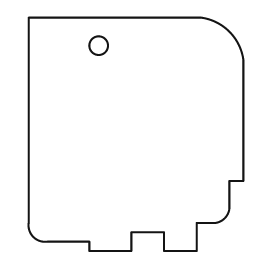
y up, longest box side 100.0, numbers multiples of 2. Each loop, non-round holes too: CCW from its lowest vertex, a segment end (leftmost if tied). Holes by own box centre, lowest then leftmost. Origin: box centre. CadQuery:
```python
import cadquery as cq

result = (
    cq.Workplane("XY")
    .moveTo(-20.0, -50.0)
    .lineTo(-2.0, -50.0)
    .lineTo(-2.0, -42.0)
    .lineTo(12.0, -42.0)
    .lineTo(12.0, -50.0)
    .lineTo(26.0, -50.0)
    .lineTo(26.0, -38.0)
    .lineTo(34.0, -38.0)
    .threePointArc((38.0, -36.0), (40.0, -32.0))
    .lineTo(40.0, -20.0)
    .lineTo(46.0, -20.0)
    .lineTo(46.0, 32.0)
    .threePointArc((40.0, 44.0), (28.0, 50.0))
    .lineTo(-46.0, 50.0)
    .lineTo(-46.0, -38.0)
    .threePointArc((-44.0, -44.0), (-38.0, -46.0))
    .lineTo(-20.0, -46.0)
    .close()
    .moveTo(-16.0, 38.0)
    .circle(4.0)
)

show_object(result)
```